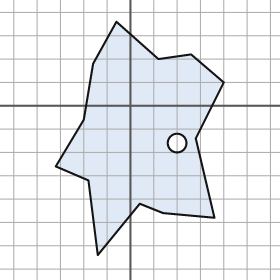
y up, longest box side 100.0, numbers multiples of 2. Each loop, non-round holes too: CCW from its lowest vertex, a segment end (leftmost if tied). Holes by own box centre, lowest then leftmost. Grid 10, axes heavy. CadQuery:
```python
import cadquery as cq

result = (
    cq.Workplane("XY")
    .moveTo(-14.0, -64.0)
    .lineTo(4.0, -42.0)
    .lineTo(14.0, -46.0)
    .lineTo(36.0, -48.0)
    .lineTo(28.0, -14.0)
    .lineTo(40.0, 10.0)
    .lineTo(26.0, 22.0)
    .lineTo(12.0, 20.0)
    .lineTo(-6.0, 36.0)
    .lineTo(-16.0, 18.0)
    .lineTo(-20.0, -6.0)
    .lineTo(-32.0, -26.0)
    .lineTo(-18.0, -32.0)
    .close()
    .moveTo(20.0, -16.0)
    .circle(4.0)
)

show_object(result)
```